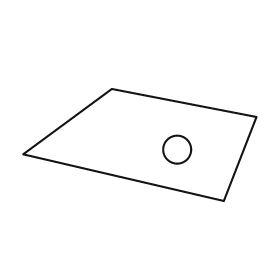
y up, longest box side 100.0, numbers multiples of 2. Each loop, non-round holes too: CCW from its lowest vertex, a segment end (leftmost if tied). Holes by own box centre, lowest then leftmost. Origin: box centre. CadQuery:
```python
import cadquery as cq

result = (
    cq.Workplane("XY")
    .moveTo(36.0, -24.0)
    .lineTo(50.0, 12.0)
    .lineTo(-12.0, 24.0)
    .lineTo(-50.0, -4.0)
    .close()
    .moveTo(16.0, -2.0)
    .circle(6.0)
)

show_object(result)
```